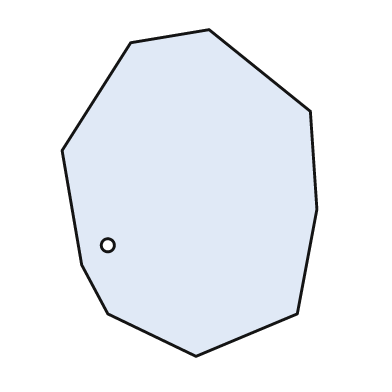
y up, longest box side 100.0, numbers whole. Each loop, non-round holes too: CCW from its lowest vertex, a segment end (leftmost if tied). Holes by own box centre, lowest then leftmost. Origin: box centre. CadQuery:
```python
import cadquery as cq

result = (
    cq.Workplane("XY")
    .moveTo(2.0, -50.0)
    .lineTo(33.0, -37.0)
    .lineTo(39.0, -5.0)
    .lineTo(37.0, 25.0)
    .lineTo(6.0, 50.0)
    .lineTo(-18.0, 46.0)
    .lineTo(-39.0, 13.0)
    .lineTo(-33.0, -22.0)
    .lineTo(-25.0, -37.0)
    .close()
    .moveTo(-25.0, -16.0)
    .circle(2.0)
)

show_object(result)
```